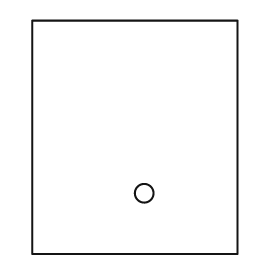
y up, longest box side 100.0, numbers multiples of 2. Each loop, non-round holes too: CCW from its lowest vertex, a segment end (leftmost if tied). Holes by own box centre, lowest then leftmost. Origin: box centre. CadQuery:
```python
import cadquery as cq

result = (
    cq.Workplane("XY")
    .moveTo(-44.0, -50.0)
    .lineTo(44.0, -50.0)
    .lineTo(44.0, 50.0)
    .lineTo(-44.0, 50.0)
    .close()
    .moveTo(4.0, -24.0)
    .circle(4.0)
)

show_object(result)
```